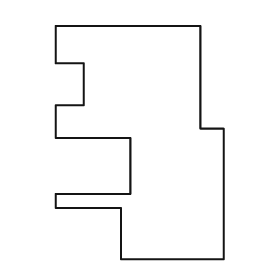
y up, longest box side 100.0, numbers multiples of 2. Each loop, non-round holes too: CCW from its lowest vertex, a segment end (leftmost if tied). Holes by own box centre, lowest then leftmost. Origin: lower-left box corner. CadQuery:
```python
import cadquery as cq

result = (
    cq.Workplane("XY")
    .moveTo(28.0, 0.0)
    .lineTo(72.0, 0.0)
    .lineTo(72.0, 56.0)
    .lineTo(62.0, 56.0)
    .lineTo(62.0, 100.0)
    .lineTo(0.0, 100.0)
    .lineTo(0.0, 84.0)
    .lineTo(12.0, 84.0)
    .lineTo(12.0, 66.0)
    .lineTo(0.0, 66.0)
    .lineTo(0.0, 52.0)
    .lineTo(32.0, 52.0)
    .lineTo(32.0, 28.0)
    .lineTo(0.0, 28.0)
    .lineTo(0.0, 22.0)
    .lineTo(28.0, 22.0)
    .close()
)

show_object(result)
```